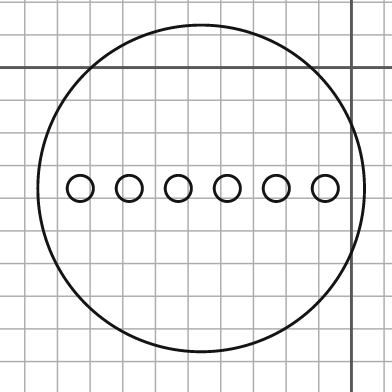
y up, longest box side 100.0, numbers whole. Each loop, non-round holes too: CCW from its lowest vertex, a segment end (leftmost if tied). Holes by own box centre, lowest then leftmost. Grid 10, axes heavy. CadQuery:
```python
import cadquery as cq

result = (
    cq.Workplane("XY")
    .moveTo(-46.0, -37.0)
    .circle(50.0)
    .moveTo(-83.0, -37.0)
    .circle(4.0)
    .moveTo(-68.0, -37.0)
    .circle(4.0)
    .moveTo(-53.0, -37.0)
    .circle(4.0)
    .moveTo(-38.0, -37.0)
    .circle(4.0)
    .moveTo(-23.0, -37.0)
    .circle(4.0)
    .moveTo(-8.0, -37.0)
    .circle(4.0)
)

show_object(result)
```